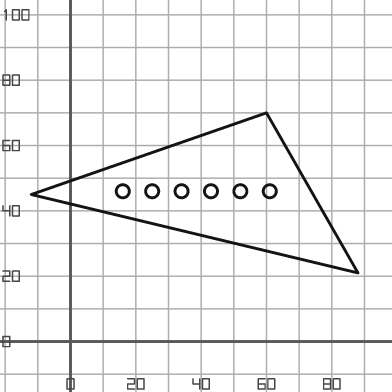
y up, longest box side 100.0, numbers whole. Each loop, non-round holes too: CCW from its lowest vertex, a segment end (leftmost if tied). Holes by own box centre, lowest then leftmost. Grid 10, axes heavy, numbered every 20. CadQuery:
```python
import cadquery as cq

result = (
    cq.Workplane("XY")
    .moveTo(88.0, 21.0)
    .lineTo(60.0, 70.0)
    .lineTo(-12.0, 45.0)
    .close()
    .moveTo(16.0, 46.0)
    .circle(2.0)
    .moveTo(25.0, 46.0)
    .circle(2.0)
    .moveTo(34.0, 46.0)
    .circle(2.0)
    .moveTo(43.0, 46.0)
    .circle(2.0)
    .moveTo(52.0, 46.0)
    .circle(2.0)
    .moveTo(61.0, 46.0)
    .circle(2.0)
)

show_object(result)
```